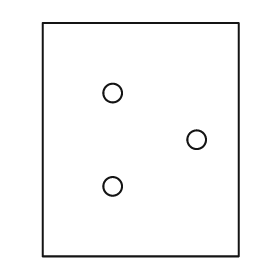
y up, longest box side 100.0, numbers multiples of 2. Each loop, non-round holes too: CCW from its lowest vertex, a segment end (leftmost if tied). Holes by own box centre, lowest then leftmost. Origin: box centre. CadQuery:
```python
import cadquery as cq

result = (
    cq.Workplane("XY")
    .moveTo(-42.0, -50.0)
    .lineTo(42.0, -50.0)
    .lineTo(42.0, 50.0)
    .lineTo(-42.0, 50.0)
    .close()
    .moveTo(-12.0, -20.0)
    .circle(4.0)
    .moveTo(24.0, 0.0)
    .circle(4.0)
    .moveTo(-12.0, 20.0)
    .circle(4.0)
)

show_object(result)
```